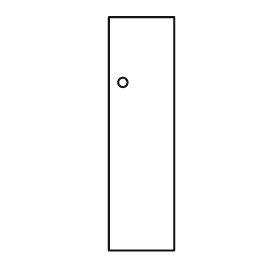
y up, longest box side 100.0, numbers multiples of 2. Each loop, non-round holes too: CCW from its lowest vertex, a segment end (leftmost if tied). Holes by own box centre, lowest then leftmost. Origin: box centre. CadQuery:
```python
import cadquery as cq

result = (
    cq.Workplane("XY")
    .moveTo(-14.0, -50.0)
    .lineTo(14.0, -50.0)
    .lineTo(14.0, 50.0)
    .lineTo(-14.0, 50.0)
    .close()
    .moveTo(-8.0, 22.0)
    .circle(2.0)
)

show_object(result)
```